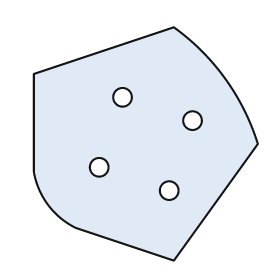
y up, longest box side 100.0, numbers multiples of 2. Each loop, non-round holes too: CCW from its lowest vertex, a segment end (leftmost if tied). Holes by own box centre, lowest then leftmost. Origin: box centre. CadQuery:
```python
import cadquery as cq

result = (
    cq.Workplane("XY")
    .moveTo(12.0, -50.0)
    .lineTo(48.0, 0.0)
    .threePointArc((34.0, 28.0), (12.0, 50.0))
    .lineTo(-48.0, 30.0)
    .lineTo(-48.0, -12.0)
    .threePointArc((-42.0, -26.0), (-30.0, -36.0))
    .close()
    .moveTo(10.0, -20.0)
    .circle(4.0)
    .moveTo(-20.0, -10.0)
    .circle(4.0)
    .moveTo(20.0, 10.0)
    .circle(4.0)
    .moveTo(-10.0, 20.0)
    .circle(4.0)
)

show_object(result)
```